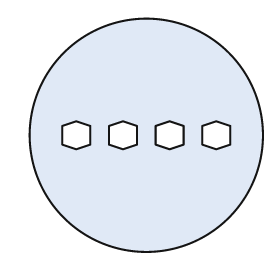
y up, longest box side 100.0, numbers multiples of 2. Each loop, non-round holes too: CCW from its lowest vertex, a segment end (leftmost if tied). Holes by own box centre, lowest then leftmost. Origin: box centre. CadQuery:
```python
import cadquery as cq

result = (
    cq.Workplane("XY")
    .moveTo(0.0, 0.0)
    .circle(50.0)
    .moveTo(-30.0, -6.0)
    .lineTo(-24.0, -4.0)
    .lineTo(-24.0, 4.0)
    .lineTo(-30.0, 6.0)
    .lineTo(-36.0, 4.0)
    .lineTo(-36.0, -4.0)
    .close()
    .moveTo(-10.0, -6.0)
    .lineTo(-4.0, -4.0)
    .lineTo(-4.0, 4.0)
    .lineTo(-10.0, 6.0)
    .lineTo(-16.0, 4.0)
    .lineTo(-16.0, -4.0)
    .close()
    .moveTo(10.0, -6.0)
    .lineTo(16.0, -4.0)
    .lineTo(16.0, 4.0)
    .lineTo(10.0, 6.0)
    .lineTo(4.0, 4.0)
    .lineTo(4.0, -4.0)
    .close()
    .moveTo(30.0, -6.0)
    .lineTo(36.0, -4.0)
    .lineTo(36.0, 4.0)
    .lineTo(30.0, 6.0)
    .lineTo(24.0, 4.0)
    .lineTo(24.0, -4.0)
    .close()
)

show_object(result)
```